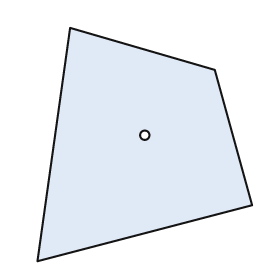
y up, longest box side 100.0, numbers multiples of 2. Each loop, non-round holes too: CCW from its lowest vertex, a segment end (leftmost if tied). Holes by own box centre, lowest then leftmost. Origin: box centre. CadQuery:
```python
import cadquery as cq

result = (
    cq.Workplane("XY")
    .moveTo(-46.0, -50.0)
    .lineTo(46.0, -26.0)
    .lineTo(30.0, 32.0)
    .lineTo(-32.0, 50.0)
    .close()
    .moveTo(0.0, 4.0)
    .circle(2.0)
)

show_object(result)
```